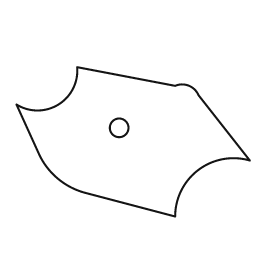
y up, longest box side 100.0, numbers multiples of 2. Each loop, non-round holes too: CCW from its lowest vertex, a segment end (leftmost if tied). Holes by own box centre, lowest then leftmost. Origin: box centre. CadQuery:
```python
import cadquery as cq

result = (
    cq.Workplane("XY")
    .moveTo(18.0, -32.0)
    .threePointArc((28.0, -12.0), (50.0, -8.0))
    .lineTo(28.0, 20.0)
    .threePointArc((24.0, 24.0), (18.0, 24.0))
    .lineTo(-24.0, 32.0)
    .threePointArc((-32.0, 16.0), (-50.0, 16.0))
    .lineTo(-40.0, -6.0)
    .threePointArc((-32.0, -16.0), (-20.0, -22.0))
    .close()
    .moveTo(-6.0, 6.0)
    .circle(4.0)
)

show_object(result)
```